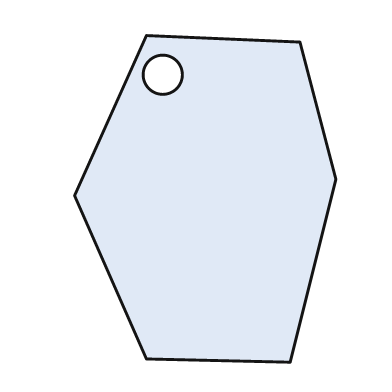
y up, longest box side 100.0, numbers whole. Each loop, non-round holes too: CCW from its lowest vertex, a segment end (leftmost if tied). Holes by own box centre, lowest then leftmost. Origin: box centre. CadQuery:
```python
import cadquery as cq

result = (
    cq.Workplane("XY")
    .moveTo(26.0, -50.0)
    .lineTo(40.0, 6.0)
    .lineTo(29.0, 48.0)
    .lineTo(-18.0, 50.0)
    .lineTo(-40.0, 1.0)
    .lineTo(-18.0, -49.0)
    .close()
    .moveTo(-13.0, 38.0)
    .circle(6.0)
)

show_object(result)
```